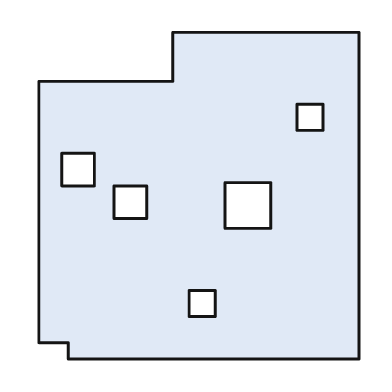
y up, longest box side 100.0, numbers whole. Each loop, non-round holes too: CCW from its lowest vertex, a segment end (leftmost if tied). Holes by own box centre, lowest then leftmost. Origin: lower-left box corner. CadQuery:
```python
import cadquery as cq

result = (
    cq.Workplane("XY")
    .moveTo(9.0, 0.0)
    .lineTo(98.0, 0.0)
    .lineTo(98.0, 100.0)
    .lineTo(41.0, 100.0)
    .lineTo(41.0, 85.0)
    .lineTo(0.0, 85.0)
    .lineTo(0.0, 5.0)
    .lineTo(9.0, 5.0)
    .close()
    .moveTo(46.0, 13.0)
    .lineTo(54.0, 13.0)
    .lineTo(54.0, 21.0)
    .lineTo(46.0, 21.0)
    .close()
    .moveTo(57.0, 40.0)
    .lineTo(71.0, 40.0)
    .lineTo(71.0, 54.0)
    .lineTo(57.0, 54.0)
    .close()
    .moveTo(23.0, 43.0)
    .lineTo(33.0, 43.0)
    .lineTo(33.0, 53.0)
    .lineTo(23.0, 53.0)
    .close()
    .moveTo(7.0, 53.0)
    .lineTo(17.0, 53.0)
    .lineTo(17.0, 63.0)
    .lineTo(7.0, 63.0)
    .close()
    .moveTo(79.0, 70.0)
    .lineTo(87.0, 70.0)
    .lineTo(87.0, 78.0)
    .lineTo(79.0, 78.0)
    .close()
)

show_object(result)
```